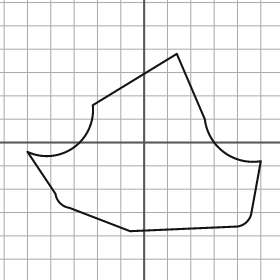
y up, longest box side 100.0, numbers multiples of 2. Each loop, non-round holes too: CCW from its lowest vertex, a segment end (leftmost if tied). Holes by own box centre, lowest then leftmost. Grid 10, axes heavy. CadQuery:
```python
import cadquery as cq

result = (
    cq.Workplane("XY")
    .moveTo(-6.0, -38.0)
    .lineTo(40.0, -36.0)
    .threePointArc((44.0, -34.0), (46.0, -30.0))
    .lineTo(50.0, -8.0)
    .threePointArc((34.0, -4.0), (26.0, 10.0))
    .lineTo(14.0, 38.0)
    .lineTo(-22.0, 16.0)
    .threePointArc((-30.0, -2.0), (-50.0, -4.0))
    .lineTo(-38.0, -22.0)
    .threePointArc((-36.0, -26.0), (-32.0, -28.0))
    .close()
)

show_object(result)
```